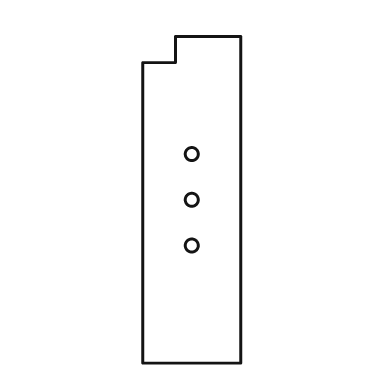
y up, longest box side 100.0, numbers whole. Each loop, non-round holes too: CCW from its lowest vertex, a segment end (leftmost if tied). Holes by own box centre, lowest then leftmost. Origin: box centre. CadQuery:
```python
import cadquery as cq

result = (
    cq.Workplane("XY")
    .moveTo(-15.0, -50.0)
    .lineTo(15.0, -50.0)
    .lineTo(15.0, 50.0)
    .lineTo(-5.0, 50.0)
    .lineTo(-5.0, 42.0)
    .lineTo(-15.0, 42.0)
    .close()
    .moveTo(0.0, -14.0)
    .circle(2.0)
    .moveTo(0.0, 0.0)
    .circle(2.0)
    .moveTo(0.0, 14.0)
    .circle(2.0)
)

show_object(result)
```